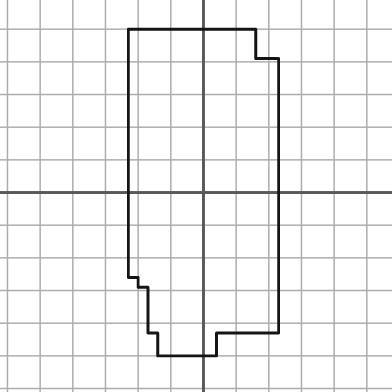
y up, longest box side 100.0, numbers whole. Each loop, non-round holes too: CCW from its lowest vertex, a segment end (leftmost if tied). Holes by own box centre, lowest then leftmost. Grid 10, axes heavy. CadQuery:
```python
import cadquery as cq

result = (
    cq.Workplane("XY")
    .moveTo(-14.0, -50.0)
    .lineTo(4.0, -50.0)
    .lineTo(4.0, -43.0)
    .lineTo(23.0, -43.0)
    .lineTo(23.0, 41.0)
    .lineTo(16.0, 41.0)
    .lineTo(16.0, 50.0)
    .lineTo(-23.0, 50.0)
    .lineTo(-23.0, -26.0)
    .lineTo(-20.0, -26.0)
    .lineTo(-20.0, -29.0)
    .lineTo(-17.0, -29.0)
    .lineTo(-17.0, -43.0)
    .lineTo(-14.0, -43.0)
    .close()
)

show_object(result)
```